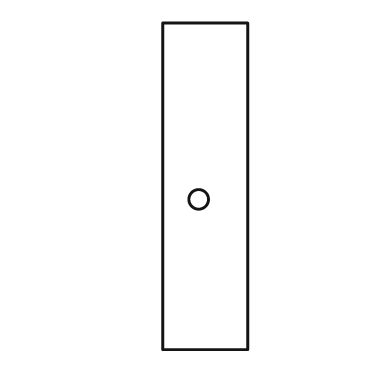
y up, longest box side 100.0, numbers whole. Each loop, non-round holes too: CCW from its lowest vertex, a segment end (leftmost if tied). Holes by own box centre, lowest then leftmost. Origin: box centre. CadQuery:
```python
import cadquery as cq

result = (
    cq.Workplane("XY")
    .moveTo(-13.0, -50.0)
    .lineTo(13.0, -50.0)
    .lineTo(13.0, 50.0)
    .lineTo(-13.0, 50.0)
    .close()
    .moveTo(-2.0, -4.0)
    .circle(3.0)
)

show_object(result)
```